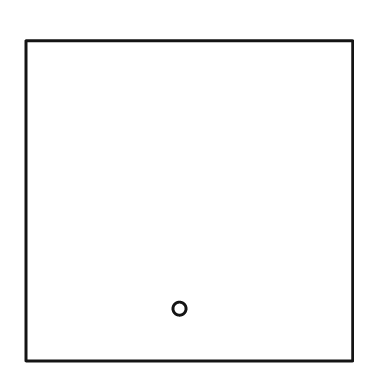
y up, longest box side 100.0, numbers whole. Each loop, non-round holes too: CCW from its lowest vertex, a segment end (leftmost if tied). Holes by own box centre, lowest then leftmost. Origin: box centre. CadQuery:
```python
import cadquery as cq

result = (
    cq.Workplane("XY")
    .moveTo(-50.0, -49.0)
    .lineTo(50.0, -49.0)
    .lineTo(50.0, 49.0)
    .lineTo(-50.0, 49.0)
    .close()
    .moveTo(-3.0, -33.0)
    .circle(2.0)
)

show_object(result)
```